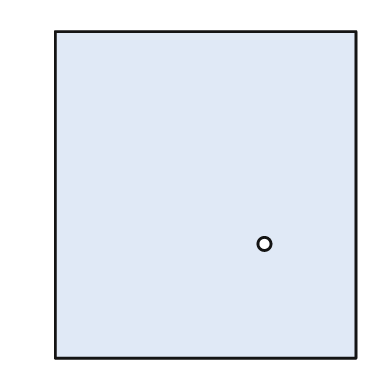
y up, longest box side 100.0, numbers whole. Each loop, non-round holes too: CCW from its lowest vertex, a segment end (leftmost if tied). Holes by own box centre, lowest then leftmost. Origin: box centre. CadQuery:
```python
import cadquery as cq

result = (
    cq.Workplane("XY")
    .moveTo(-46.0, -50.0)
    .lineTo(46.0, -50.0)
    .lineTo(46.0, 50.0)
    .lineTo(-46.0, 50.0)
    .close()
    .moveTo(18.0, -15.0)
    .circle(2.0)
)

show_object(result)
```